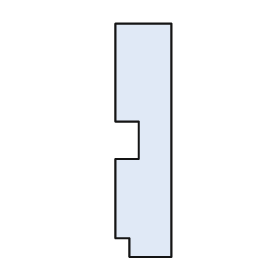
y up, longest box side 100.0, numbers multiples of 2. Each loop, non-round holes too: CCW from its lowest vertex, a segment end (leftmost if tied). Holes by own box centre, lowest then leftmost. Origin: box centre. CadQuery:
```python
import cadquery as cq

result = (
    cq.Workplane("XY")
    .moveTo(-6.0, -50.0)
    .lineTo(12.0, -50.0)
    .lineTo(12.0, 50.0)
    .lineTo(-12.0, 50.0)
    .lineTo(-12.0, 8.0)
    .lineTo(-2.0, 8.0)
    .lineTo(-2.0, -8.0)
    .lineTo(-12.0, -8.0)
    .lineTo(-12.0, -42.0)
    .lineTo(-6.0, -42.0)
    .close()
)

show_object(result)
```